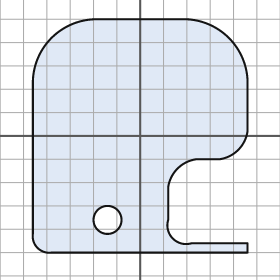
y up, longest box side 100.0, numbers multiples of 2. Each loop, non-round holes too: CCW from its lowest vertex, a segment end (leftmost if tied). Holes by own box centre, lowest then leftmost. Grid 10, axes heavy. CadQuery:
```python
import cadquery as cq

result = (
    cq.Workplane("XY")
    .moveTo(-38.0, -50.0)
    .lineTo(46.0, -50.0)
    .lineTo(46.0, -46.0)
    .lineTo(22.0, -46.0)
    .threePointArc((14.0, -44.0), (12.0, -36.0))
    .lineTo(12.0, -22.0)
    .threePointArc((16.0, -14.0), (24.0, -10.0))
    .lineTo(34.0, -10.0)
    .threePointArc((42.0, -6.0), (46.0, 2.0))
    .lineTo(46.0, 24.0)
    .threePointArc((38.0, 42.0), (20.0, 50.0))
    .lineTo(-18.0, 50.0)
    .threePointArc((-38.0, 42.0), (-46.0, 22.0))
    .lineTo(-46.0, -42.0)
    .threePointArc((-44.0, -48.0), (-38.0, -50.0))
    .close()
    .moveTo(-14.0, -36.0)
    .circle(6.0)
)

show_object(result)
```